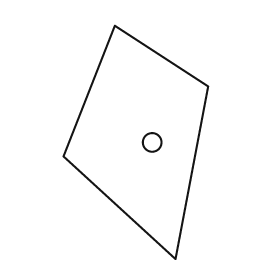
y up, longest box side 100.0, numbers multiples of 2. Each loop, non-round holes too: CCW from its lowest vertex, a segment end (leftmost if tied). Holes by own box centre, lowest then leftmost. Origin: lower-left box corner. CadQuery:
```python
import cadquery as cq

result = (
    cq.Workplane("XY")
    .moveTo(48.0, 0.0)
    .lineTo(62.0, 74.0)
    .lineTo(22.0, 100.0)
    .lineTo(0.0, 44.0)
    .close()
    .moveTo(38.0, 50.0)
    .circle(4.0)
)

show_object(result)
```